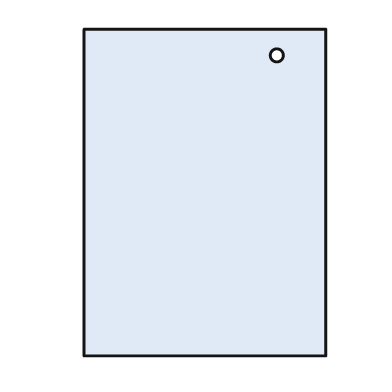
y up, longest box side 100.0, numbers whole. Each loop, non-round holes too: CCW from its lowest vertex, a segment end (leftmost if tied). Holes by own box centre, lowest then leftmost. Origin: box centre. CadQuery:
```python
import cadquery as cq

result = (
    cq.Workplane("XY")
    .moveTo(-37.0, -50.0)
    .lineTo(37.0, -50.0)
    .lineTo(37.0, 50.0)
    .lineTo(-37.0, 50.0)
    .close()
    .moveTo(22.0, 42.0)
    .circle(2.0)
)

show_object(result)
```